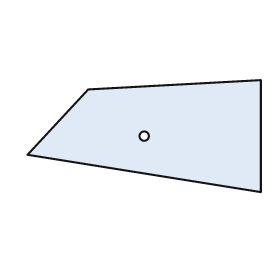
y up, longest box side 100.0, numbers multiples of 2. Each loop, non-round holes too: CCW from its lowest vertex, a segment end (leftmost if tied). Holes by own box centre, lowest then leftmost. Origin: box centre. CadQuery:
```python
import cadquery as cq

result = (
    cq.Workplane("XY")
    .moveTo(50.0, -24.0)
    .lineTo(50.0, 24.0)
    .lineTo(-24.0, 20.0)
    .lineTo(-50.0, -8.0)
    .close()
    .moveTo(0.0, 0.0)
    .circle(2.0)
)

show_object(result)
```